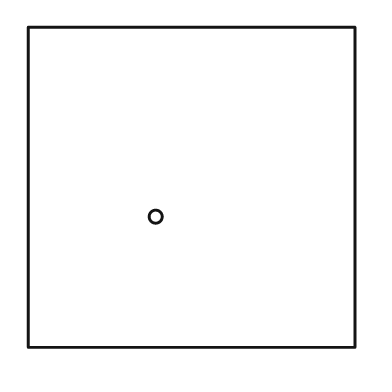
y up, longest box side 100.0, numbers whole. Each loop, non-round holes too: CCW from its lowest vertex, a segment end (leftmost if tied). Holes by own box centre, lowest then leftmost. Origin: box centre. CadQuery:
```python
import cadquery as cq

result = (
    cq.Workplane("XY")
    .moveTo(-50.0, -49.0)
    .lineTo(50.0, -49.0)
    .lineTo(50.0, 49.0)
    .lineTo(-50.0, 49.0)
    .close()
    .moveTo(-11.0, -9.0)
    .circle(2.0)
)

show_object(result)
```